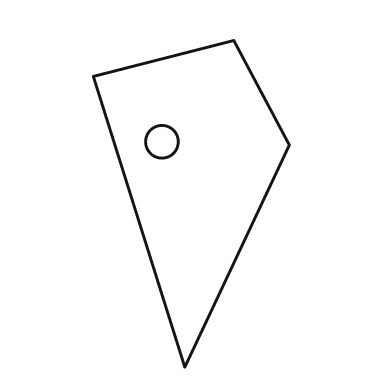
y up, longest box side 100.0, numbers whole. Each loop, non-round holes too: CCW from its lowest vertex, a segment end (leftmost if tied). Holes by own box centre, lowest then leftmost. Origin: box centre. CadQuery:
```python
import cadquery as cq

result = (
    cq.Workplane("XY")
    .moveTo(-2.0, -50.0)
    .lineTo(30.0, 18.0)
    .lineTo(13.0, 50.0)
    .lineTo(-30.0, 39.0)
    .close()
    .moveTo(-9.0, 19.0)
    .circle(5.0)
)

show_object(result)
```